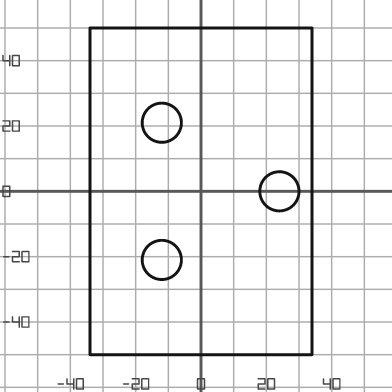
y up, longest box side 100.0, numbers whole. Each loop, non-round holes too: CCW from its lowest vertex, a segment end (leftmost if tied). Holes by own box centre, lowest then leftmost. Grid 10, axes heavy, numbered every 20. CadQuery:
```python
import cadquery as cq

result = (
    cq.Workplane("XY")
    .moveTo(-34.0, -50.0)
    .lineTo(34.0, -50.0)
    .lineTo(34.0, 50.0)
    .lineTo(-34.0, 50.0)
    .close()
    .moveTo(-12.0, -21.0)
    .circle(6.0)
    .moveTo(24.0, 0.0)
    .circle(6.0)
    .moveTo(-12.0, 21.0)
    .circle(6.0)
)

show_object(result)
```